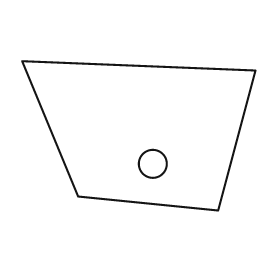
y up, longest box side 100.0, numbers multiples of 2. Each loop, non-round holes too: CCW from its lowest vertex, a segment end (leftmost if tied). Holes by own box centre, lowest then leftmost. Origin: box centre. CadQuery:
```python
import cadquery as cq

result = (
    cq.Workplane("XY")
    .moveTo(34.0, -32.0)
    .lineTo(50.0, 28.0)
    .lineTo(-50.0, 32.0)
    .lineTo(-26.0, -26.0)
    .close()
    .moveTo(6.0, -12.0)
    .circle(6.0)
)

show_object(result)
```